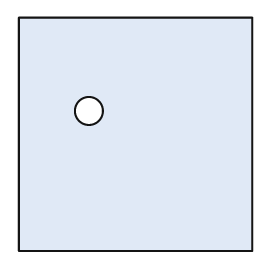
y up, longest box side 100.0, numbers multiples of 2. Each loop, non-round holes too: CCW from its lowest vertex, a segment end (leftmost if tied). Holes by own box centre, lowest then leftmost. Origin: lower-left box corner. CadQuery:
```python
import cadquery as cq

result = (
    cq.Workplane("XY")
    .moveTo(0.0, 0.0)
    .lineTo(100.0, 0.0)
    .lineTo(100.0, 100.0)
    .lineTo(0.0, 100.0)
    .close()
    .moveTo(30.0, 60.0)
    .circle(6.0)
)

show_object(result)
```